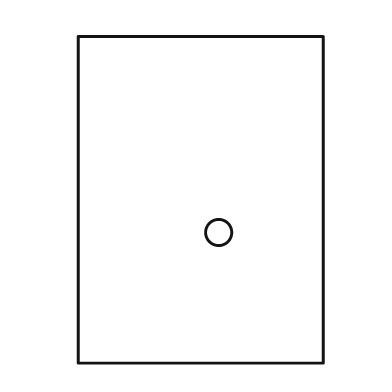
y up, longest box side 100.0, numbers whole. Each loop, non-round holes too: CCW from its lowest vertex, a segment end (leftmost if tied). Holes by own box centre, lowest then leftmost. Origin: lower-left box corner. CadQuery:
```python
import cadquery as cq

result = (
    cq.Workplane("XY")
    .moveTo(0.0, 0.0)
    .lineTo(75.0, 0.0)
    .lineTo(75.0, 100.0)
    .lineTo(0.0, 100.0)
    .close()
    .moveTo(43.0, 40.0)
    .circle(4.0)
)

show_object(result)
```